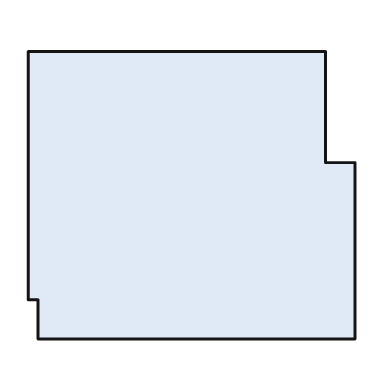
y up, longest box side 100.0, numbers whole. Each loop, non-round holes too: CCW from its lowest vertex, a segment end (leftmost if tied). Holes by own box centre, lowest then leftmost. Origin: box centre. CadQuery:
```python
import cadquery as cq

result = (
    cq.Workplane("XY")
    .moveTo(-47.0, -44.0)
    .lineTo(50.0, -44.0)
    .lineTo(50.0, 10.0)
    .lineTo(41.0, 10.0)
    .lineTo(41.0, 44.0)
    .lineTo(-50.0, 44.0)
    .lineTo(-50.0, -32.0)
    .lineTo(-47.0, -32.0)
    .close()
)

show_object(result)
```